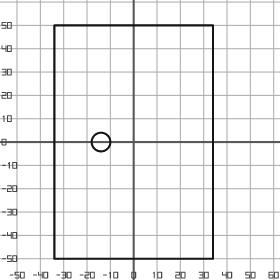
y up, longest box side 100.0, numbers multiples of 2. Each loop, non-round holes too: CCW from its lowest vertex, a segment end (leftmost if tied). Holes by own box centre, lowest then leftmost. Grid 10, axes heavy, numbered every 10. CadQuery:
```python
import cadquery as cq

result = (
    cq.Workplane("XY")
    .moveTo(-34.0, -50.0)
    .lineTo(34.0, -50.0)
    .lineTo(34.0, 50.0)
    .lineTo(-34.0, 50.0)
    .close()
    .moveTo(-14.0, 0.0)
    .circle(4.0)
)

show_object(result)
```